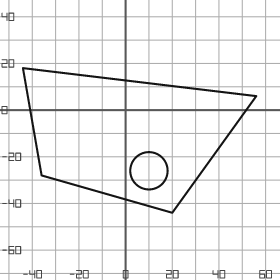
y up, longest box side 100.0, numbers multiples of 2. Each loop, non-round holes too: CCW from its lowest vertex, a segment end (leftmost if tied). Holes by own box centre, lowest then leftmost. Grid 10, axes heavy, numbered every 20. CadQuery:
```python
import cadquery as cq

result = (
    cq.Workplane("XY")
    .moveTo(20.0, -44.0)
    .lineTo(56.0, 6.0)
    .lineTo(-44.0, 18.0)
    .lineTo(-36.0, -28.0)
    .close()
    .moveTo(10.0, -26.0)
    .circle(8.0)
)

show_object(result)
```